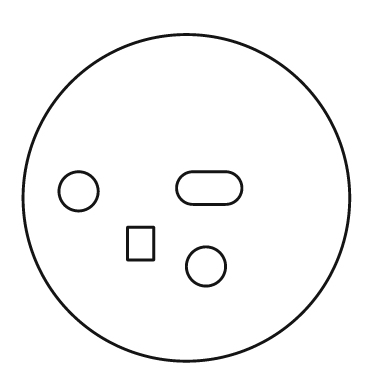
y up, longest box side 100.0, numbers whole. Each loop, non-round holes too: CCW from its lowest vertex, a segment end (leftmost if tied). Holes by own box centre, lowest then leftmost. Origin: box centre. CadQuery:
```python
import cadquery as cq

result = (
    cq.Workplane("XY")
    .moveTo(0.0, 0.0)
    .circle(50.0)
    .moveTo(6.0, -21.0)
    .circle(6.0)
    .moveTo(-18.0, -19.0)
    .lineTo(-10.0, -19.0)
    .lineTo(-10.0, -9.0)
    .lineTo(-18.0, -9.0)
    .close()
    .moveTo(-33.0, 2.0)
    .circle(6.0)
    .moveTo(2.0, -2.0)
    .lineTo(12.0, -2.0)
    .threePointArc((17.0, 3.0), (12.0, 8.0))
    .lineTo(2.0, 8.0)
    .threePointArc((-3.0, 3.0), (2.0, -2.0))
    .close()
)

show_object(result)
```